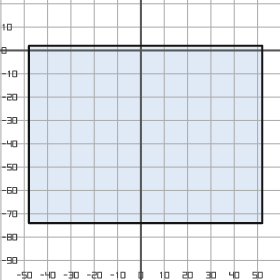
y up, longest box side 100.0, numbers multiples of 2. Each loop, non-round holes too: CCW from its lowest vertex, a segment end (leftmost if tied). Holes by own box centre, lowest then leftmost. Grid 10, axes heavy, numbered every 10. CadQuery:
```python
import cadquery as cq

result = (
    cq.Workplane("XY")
    .moveTo(-48.0, -74.0)
    .lineTo(52.0, -74.0)
    .lineTo(52.0, 2.0)
    .lineTo(-48.0, 2.0)
    .close()
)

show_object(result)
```